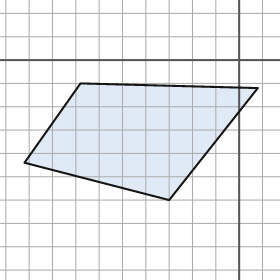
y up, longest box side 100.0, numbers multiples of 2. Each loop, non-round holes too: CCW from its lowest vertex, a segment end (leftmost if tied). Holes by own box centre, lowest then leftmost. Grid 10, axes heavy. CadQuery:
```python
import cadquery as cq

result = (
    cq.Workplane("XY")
    .moveTo(-30.0, -60.0)
    .lineTo(8.0, -12.0)
    .lineTo(-68.0, -10.0)
    .lineTo(-92.0, -44.0)
    .close()
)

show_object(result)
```